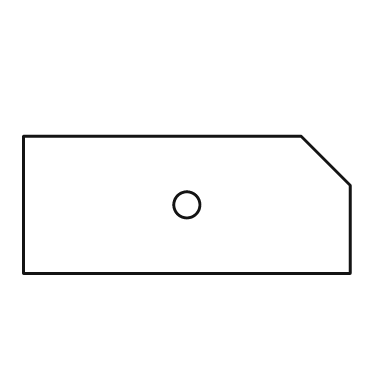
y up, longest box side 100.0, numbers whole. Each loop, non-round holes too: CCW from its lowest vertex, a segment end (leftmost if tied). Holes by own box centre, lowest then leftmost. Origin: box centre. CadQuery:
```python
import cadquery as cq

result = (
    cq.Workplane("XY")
    .moveTo(-50.0, -21.0)
    .lineTo(50.0, -21.0)
    .lineTo(50.0, 6.0)
    .lineTo(35.0, 21.0)
    .lineTo(-50.0, 21.0)
    .close()
    .moveTo(0.0, 0.0)
    .circle(4.0)
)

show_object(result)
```